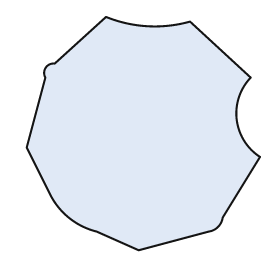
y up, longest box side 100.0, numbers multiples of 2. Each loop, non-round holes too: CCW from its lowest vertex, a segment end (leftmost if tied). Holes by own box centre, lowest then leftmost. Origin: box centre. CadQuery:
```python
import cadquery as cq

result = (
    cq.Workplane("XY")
    .moveTo(-2.0, -50.0)
    .lineTo(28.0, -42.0)
    .threePointArc((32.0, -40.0), (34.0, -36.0))
    .lineTo(50.0, -10.0)
    .threePointArc((40.0, 6.0), (46.0, 24.0))
    .lineTo(20.0, 48.0)
    .threePointArc((2.0, 46.0), (-16.0, 50.0))
    .lineTo(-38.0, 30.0)
    .threePointArc((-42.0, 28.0), (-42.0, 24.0))
    .lineTo(-50.0, -6.0)
    .lineTo(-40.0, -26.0)
    .threePointArc((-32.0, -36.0), (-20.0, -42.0))
    .close()
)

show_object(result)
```